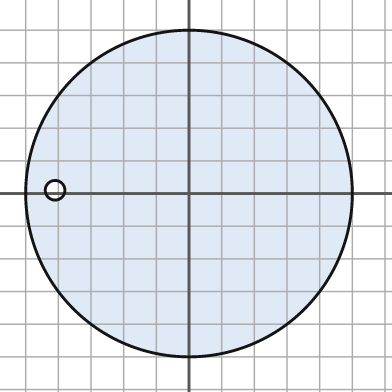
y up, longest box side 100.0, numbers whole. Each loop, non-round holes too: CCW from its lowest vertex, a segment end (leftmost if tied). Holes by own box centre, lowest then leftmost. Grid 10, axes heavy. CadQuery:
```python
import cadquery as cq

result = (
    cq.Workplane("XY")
    .moveTo(0.0, 0.0)
    .circle(50.0)
    .moveTo(-41.0, 1.0)
    .circle(3.0)
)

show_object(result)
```